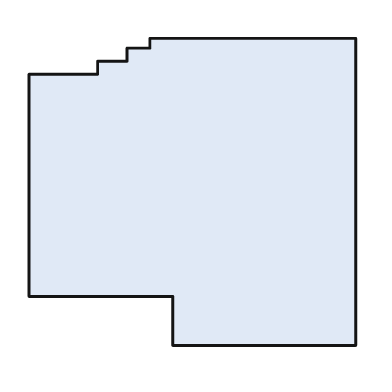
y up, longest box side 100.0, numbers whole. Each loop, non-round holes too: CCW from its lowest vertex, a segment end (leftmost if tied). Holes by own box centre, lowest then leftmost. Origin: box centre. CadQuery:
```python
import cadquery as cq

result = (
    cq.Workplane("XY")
    .moveTo(-6.0, -47.0)
    .lineTo(50.0, -47.0)
    .lineTo(50.0, 47.0)
    .lineTo(-13.0, 47.0)
    .lineTo(-13.0, 44.0)
    .lineTo(-20.0, 44.0)
    .lineTo(-20.0, 40.0)
    .lineTo(-29.0, 40.0)
    .lineTo(-29.0, 36.0)
    .lineTo(-50.0, 36.0)
    .lineTo(-50.0, -32.0)
    .lineTo(-6.0, -32.0)
    .close()
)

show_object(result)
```